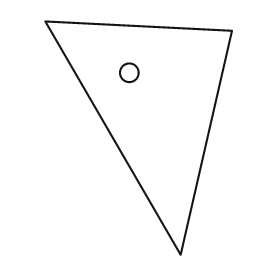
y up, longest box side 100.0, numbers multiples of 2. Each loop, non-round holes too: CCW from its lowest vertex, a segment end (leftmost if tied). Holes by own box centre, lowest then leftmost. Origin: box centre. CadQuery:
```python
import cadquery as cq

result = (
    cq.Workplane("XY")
    .moveTo(18.0, -50.0)
    .lineTo(40.0, 46.0)
    .lineTo(-40.0, 50.0)
    .close()
    .moveTo(-4.0, 28.0)
    .circle(4.0)
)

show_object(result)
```